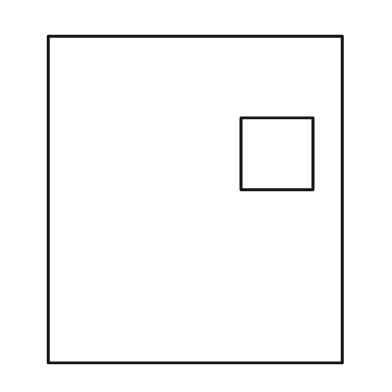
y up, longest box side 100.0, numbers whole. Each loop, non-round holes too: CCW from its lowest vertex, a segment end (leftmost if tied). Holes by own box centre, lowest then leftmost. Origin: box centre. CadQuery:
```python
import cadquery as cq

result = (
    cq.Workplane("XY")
    .moveTo(-45.0, -50.0)
    .lineTo(45.0, -50.0)
    .lineTo(45.0, 50.0)
    .lineTo(-45.0, 50.0)
    .close()
    .moveTo(14.0, 3.0)
    .lineTo(36.0, 3.0)
    .lineTo(36.0, 25.0)
    .lineTo(14.0, 25.0)
    .close()
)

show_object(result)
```